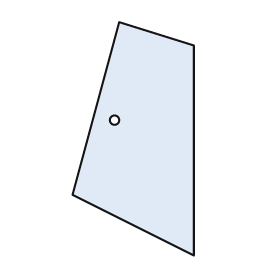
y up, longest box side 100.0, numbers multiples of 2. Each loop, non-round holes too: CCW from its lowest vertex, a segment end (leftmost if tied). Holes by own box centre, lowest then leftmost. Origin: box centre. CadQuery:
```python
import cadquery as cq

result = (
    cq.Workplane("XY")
    .moveTo(26.0, -50.0)
    .lineTo(26.0, 40.0)
    .lineTo(-6.0, 50.0)
    .lineTo(-26.0, -24.0)
    .close()
    .moveTo(-8.0, 8.0)
    .circle(2.0)
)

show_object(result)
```